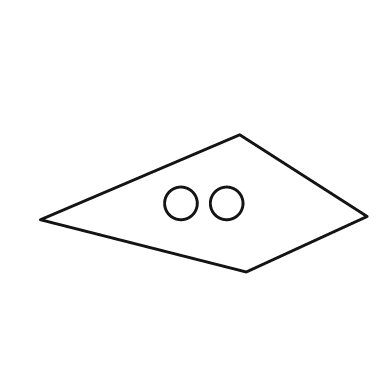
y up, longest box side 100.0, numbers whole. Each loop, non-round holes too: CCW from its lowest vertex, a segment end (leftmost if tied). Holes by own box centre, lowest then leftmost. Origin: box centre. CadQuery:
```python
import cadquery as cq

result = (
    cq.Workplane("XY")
    .moveTo(13.0, -21.0)
    .lineTo(50.0, -4.0)
    .lineTo(11.0, 21.0)
    .lineTo(-50.0, -5.0)
    .close()
    .moveTo(-7.0, 0.0)
    .circle(5.0)
    .moveTo(7.0, 0.0)
    .circle(5.0)
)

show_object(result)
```